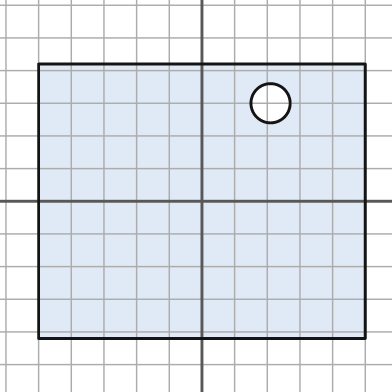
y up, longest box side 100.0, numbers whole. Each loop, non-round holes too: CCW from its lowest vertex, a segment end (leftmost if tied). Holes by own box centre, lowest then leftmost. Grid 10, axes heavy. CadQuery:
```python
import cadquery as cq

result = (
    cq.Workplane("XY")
    .moveTo(-50.0, -42.0)
    .lineTo(50.0, -42.0)
    .lineTo(50.0, 42.0)
    .lineTo(-50.0, 42.0)
    .close()
    .moveTo(21.0, 30.0)
    .circle(6.0)
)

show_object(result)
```